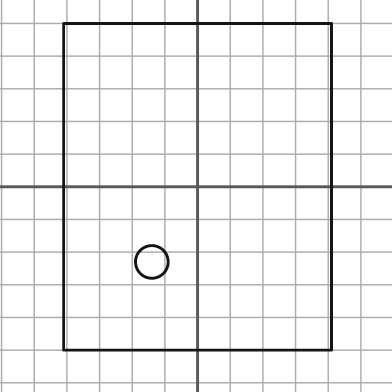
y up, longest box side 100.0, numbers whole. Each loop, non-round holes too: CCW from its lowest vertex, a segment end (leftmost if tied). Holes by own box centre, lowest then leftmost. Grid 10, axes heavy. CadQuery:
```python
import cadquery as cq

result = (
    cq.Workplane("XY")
    .moveTo(-41.0, -50.0)
    .lineTo(41.0, -50.0)
    .lineTo(41.0, 50.0)
    .lineTo(-41.0, 50.0)
    .close()
    .moveTo(-14.0, -23.0)
    .circle(5.0)
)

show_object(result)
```